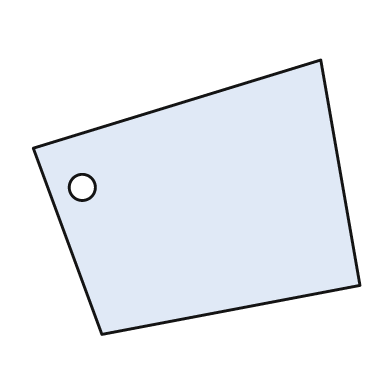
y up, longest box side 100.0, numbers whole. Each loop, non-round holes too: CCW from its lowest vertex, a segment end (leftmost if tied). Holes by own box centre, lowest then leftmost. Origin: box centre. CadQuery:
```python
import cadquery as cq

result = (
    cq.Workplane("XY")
    .moveTo(-29.0, -42.0)
    .lineTo(50.0, -27.0)
    .lineTo(38.0, 42.0)
    .lineTo(-50.0, 15.0)
    .close()
    .moveTo(-35.0, 3.0)
    .circle(4.0)
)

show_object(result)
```